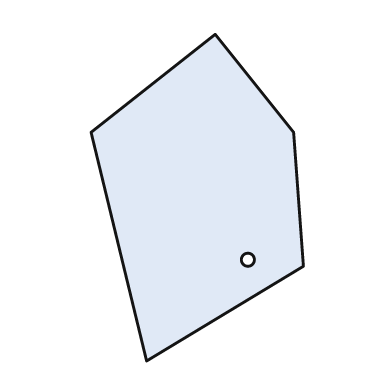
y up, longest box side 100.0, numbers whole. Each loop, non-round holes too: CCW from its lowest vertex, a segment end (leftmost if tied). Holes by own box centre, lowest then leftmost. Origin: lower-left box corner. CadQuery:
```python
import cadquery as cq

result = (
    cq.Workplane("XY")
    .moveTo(17.0, 0.0)
    .lineTo(65.0, 29.0)
    .lineTo(62.0, 70.0)
    .lineTo(38.0, 100.0)
    .lineTo(0.0, 70.0)
    .close()
    .moveTo(48.0, 31.0)
    .circle(2.0)
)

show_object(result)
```